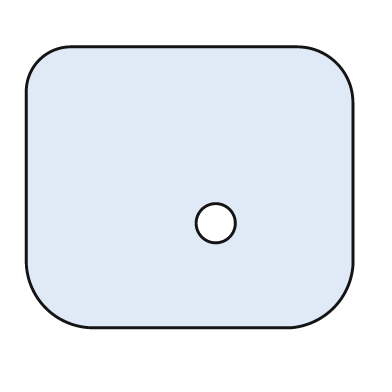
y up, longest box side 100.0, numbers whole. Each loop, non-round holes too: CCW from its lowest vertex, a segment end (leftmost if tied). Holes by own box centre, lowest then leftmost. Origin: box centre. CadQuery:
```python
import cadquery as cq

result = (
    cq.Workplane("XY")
    .moveTo(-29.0, -43.0)
    .lineTo(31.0, -43.0)
    .threePointArc((44.0, -37.0), (50.0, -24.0))
    .lineTo(50.0, 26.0)
    .threePointArc((45.0, 38.0), (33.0, 43.0))
    .lineTo(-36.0, 43.0)
    .threePointArc((-46.0, 39.0), (-50.0, 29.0))
    .lineTo(-50.0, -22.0)
    .threePointArc((-44.0, -37.0), (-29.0, -43.0))
    .close()
    .moveTo(8.0, -11.0)
    .circle(6.0)
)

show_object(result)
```